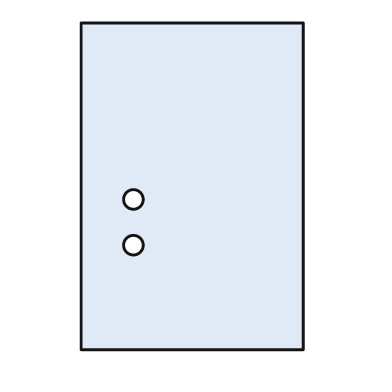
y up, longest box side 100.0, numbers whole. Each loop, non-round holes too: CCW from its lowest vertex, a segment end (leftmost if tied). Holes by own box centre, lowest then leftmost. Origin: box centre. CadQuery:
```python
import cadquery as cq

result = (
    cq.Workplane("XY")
    .moveTo(-34.0, -50.0)
    .lineTo(34.0, -50.0)
    .lineTo(34.0, 50.0)
    .lineTo(-34.0, 50.0)
    .close()
    .moveTo(-18.0, -18.0)
    .circle(3.0)
    .moveTo(-18.0, -4.0)
    .circle(3.0)
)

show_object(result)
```